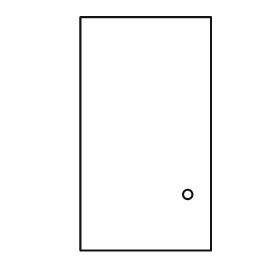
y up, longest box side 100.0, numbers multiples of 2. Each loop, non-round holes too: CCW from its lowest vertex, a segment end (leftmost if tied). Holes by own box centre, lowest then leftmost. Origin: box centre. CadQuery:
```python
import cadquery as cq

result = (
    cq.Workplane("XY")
    .moveTo(-28.0, -50.0)
    .lineTo(28.0, -50.0)
    .lineTo(28.0, 50.0)
    .lineTo(-28.0, 50.0)
    .close()
    .moveTo(18.0, -26.0)
    .circle(2.0)
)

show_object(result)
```